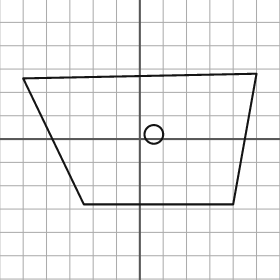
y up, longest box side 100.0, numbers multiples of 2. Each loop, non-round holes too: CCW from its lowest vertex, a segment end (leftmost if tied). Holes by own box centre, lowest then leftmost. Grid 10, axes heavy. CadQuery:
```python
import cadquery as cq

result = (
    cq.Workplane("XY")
    .moveTo(-24.0, -28.0)
    .lineTo(40.0, -28.0)
    .lineTo(50.0, 28.0)
    .lineTo(-50.0, 26.0)
    .close()
    .moveTo(6.0, 2.0)
    .circle(4.0)
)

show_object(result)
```